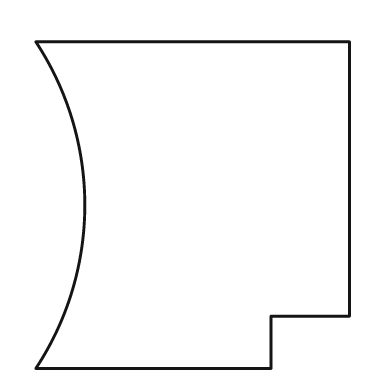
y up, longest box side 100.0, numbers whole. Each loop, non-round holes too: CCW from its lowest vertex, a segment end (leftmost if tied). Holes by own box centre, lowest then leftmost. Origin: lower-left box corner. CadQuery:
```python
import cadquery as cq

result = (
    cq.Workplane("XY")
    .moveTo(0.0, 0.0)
    .lineTo(72.0, 0.0)
    .lineTo(72.0, 16.0)
    .lineTo(96.0, 16.0)
    .lineTo(96.0, 100.0)
    .lineTo(0.0, 100.0)
    .threePointArc((15.0, 50.0), (0.0, 0.0))
    .close()
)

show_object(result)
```